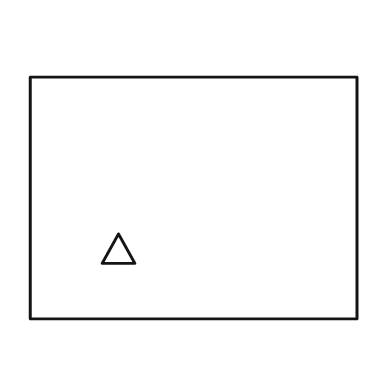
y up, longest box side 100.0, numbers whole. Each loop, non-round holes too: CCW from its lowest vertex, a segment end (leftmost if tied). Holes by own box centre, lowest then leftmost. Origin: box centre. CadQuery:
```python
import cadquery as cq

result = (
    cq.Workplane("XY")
    .moveTo(-50.0, -37.0)
    .lineTo(50.0, -37.0)
    .lineTo(50.0, 37.0)
    .lineTo(-50.0, 37.0)
    .close()
    .moveTo(-28.0, -20.0)
    .lineTo(-18.0, -20.0)
    .lineTo(-23.0, -11.0)
    .close()
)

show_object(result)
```